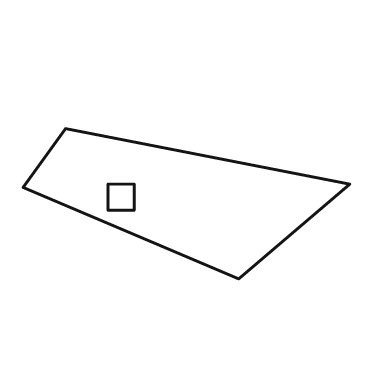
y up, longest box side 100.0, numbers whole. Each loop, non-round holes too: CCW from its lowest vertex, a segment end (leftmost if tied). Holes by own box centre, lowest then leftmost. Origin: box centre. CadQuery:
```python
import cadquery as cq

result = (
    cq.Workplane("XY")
    .moveTo(16.0, -23.0)
    .lineTo(50.0, 6.0)
    .lineTo(-37.0, 23.0)
    .lineTo(-50.0, 5.0)
    .close()
    .moveTo(-24.0, -2.0)
    .lineTo(-16.0, -2.0)
    .lineTo(-16.0, 6.0)
    .lineTo(-24.0, 6.0)
    .close()
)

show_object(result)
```